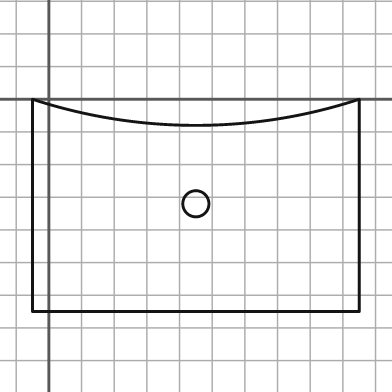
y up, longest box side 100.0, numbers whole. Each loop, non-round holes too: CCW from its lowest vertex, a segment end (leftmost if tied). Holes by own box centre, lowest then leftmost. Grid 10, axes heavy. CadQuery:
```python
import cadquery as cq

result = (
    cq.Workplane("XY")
    .moveTo(-5.0, -65.0)
    .lineTo(95.0, -65.0)
    .lineTo(95.0, 0.0)
    .threePointArc((45.0, -8.0), (-5.0, 0.0))
    .close()
    .moveTo(45.0, -32.0)
    .circle(4.0)
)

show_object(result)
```